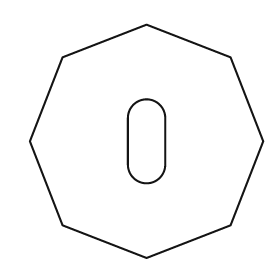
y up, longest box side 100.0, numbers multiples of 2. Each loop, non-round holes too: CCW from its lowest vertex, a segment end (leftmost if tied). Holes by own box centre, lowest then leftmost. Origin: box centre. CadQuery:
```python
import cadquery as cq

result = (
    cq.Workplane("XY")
    .moveTo(0.0, -50.0)
    .lineTo(36.0, -36.0)
    .lineTo(50.0, 0.0)
    .lineTo(36.0, 36.0)
    .lineTo(0.0, 50.0)
    .lineTo(-36.0, 36.0)
    .lineTo(-50.0, 0.0)
    .lineTo(-36.0, -36.0)
    .close()
    .moveTo(-8.0, -10.0)
    .threePointArc((0.0, -18.0), (8.0, -10.0))
    .lineTo(8.0, 10.0)
    .threePointArc((0.0, 18.0), (-8.0, 10.0))
    .close()
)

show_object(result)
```